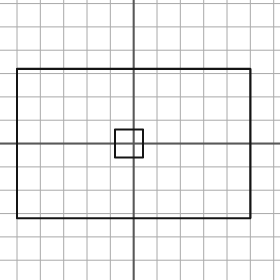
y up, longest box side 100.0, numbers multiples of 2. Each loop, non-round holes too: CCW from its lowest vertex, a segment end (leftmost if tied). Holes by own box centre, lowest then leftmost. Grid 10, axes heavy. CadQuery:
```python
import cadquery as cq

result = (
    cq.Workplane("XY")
    .moveTo(-50.0, -32.0)
    .lineTo(50.0, -32.0)
    .lineTo(50.0, 32.0)
    .lineTo(-50.0, 32.0)
    .close()
    .moveTo(-8.0, -6.0)
    .lineTo(4.0, -6.0)
    .lineTo(4.0, 6.0)
    .lineTo(-8.0, 6.0)
    .close()
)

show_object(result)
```